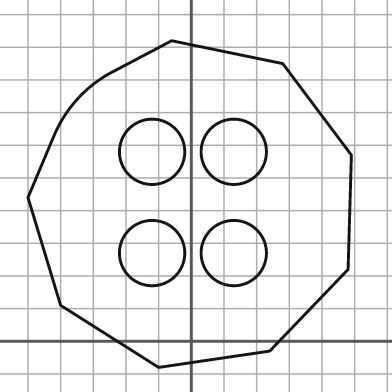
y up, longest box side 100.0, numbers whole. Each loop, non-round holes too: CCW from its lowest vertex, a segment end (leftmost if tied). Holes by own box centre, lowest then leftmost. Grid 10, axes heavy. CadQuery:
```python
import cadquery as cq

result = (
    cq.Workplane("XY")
    .moveTo(-10.0, -8.0)
    .lineTo(24.0, -3.0)
    .lineTo(48.0, 22.0)
    .lineTo(49.0, 57.0)
    .lineTo(28.0, 85.0)
    .lineTo(-6.0, 92.0)
    .lineTo(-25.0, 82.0)
    .threePointArc((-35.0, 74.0), (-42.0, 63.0))
    .lineTo(-50.0, 44.0)
    .lineTo(-40.0, 11.0)
    .close()
    .moveTo(-12.0, 27.0)
    .circle(10.0)
    .moveTo(13.0, 27.0)
    .circle(10.0)
    .moveTo(-12.0, 58.0)
    .circle(10.0)
    .moveTo(13.0, 58.0)
    .circle(10.0)
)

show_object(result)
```